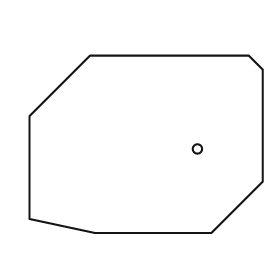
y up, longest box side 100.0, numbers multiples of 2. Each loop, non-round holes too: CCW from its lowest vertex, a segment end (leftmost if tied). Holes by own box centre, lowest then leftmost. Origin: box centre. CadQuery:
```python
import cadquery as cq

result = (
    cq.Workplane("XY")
    .moveTo(-22.0, -38.0)
    .lineTo(28.0, -38.0)
    .lineTo(50.0, -16.0)
    .lineTo(50.0, 32.0)
    .lineTo(44.0, 38.0)
    .lineTo(-24.0, 38.0)
    .lineTo(-50.0, 12.0)
    .lineTo(-50.0, -32.0)
    .close()
    .moveTo(22.0, -2.0)
    .circle(2.0)
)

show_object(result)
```